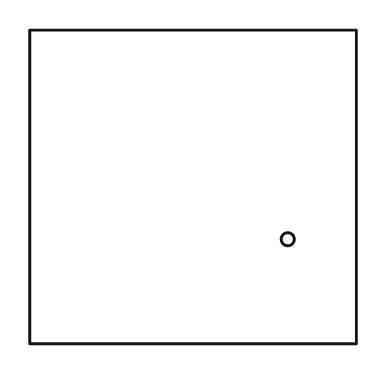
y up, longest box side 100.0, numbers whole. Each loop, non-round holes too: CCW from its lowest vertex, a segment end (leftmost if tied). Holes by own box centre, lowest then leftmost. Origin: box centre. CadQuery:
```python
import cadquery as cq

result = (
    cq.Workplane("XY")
    .moveTo(-50.0, -48.0)
    .lineTo(50.0, -48.0)
    .lineTo(50.0, 48.0)
    .lineTo(-50.0, 48.0)
    .close()
    .moveTo(29.0, -16.0)
    .circle(2.0)
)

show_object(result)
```